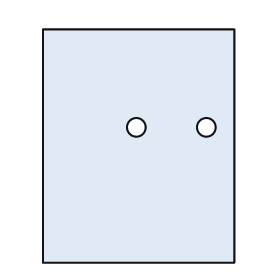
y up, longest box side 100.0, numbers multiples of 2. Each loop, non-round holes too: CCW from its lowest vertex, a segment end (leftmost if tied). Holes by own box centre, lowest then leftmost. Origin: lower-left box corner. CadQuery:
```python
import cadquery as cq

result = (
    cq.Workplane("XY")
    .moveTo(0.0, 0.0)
    .lineTo(82.0, 0.0)
    .lineTo(82.0, 100.0)
    .lineTo(0.0, 100.0)
    .close()
    .moveTo(40.0, 58.0)
    .circle(4.0)
    .moveTo(70.0, 58.0)
    .circle(4.0)
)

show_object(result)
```